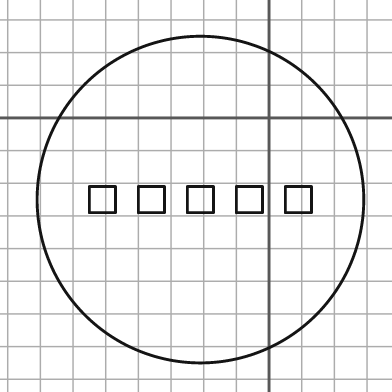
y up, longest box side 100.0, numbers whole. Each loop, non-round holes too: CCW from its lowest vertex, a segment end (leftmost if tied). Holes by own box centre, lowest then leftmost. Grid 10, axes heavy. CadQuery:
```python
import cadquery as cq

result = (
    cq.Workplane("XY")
    .moveTo(-21.0, -25.0)
    .circle(50.0)
    .moveTo(-55.0, -29.0)
    .lineTo(-47.0, -29.0)
    .lineTo(-47.0, -21.0)
    .lineTo(-55.0, -21.0)
    .close()
    .moveTo(-40.0, -29.0)
    .lineTo(-32.0, -29.0)
    .lineTo(-32.0, -21.0)
    .lineTo(-40.0, -21.0)
    .close()
    .moveTo(-25.0, -29.0)
    .lineTo(-17.0, -29.0)
    .lineTo(-17.0, -21.0)
    .lineTo(-25.0, -21.0)
    .close()
    .moveTo(-10.0, -29.0)
    .lineTo(-2.0, -29.0)
    .lineTo(-2.0, -21.0)
    .lineTo(-10.0, -21.0)
    .close()
    .moveTo(5.0, -29.0)
    .lineTo(13.0, -29.0)
    .lineTo(13.0, -21.0)
    .lineTo(5.0, -21.0)
    .close()
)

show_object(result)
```